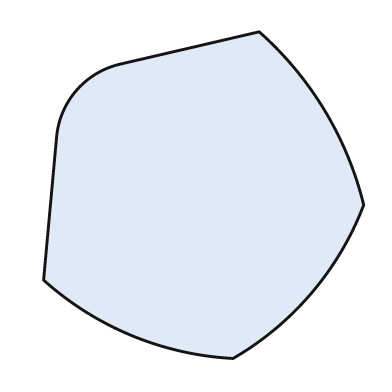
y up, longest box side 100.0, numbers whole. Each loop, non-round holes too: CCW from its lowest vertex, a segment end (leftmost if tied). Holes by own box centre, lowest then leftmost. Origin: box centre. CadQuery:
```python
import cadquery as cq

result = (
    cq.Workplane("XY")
    .moveTo(9.0, -50.0)
    .threePointArc((33.0, -30.0), (49.0, -3.0))
    .threePointArc((37.0, 26.0), (17.0, 50.0))
    .lineTo(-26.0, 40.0)
    .threePointArc((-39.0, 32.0), (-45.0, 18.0))
    .lineTo(-49.0, -26.0)
    .threePointArc((-22.0, -43.0), (9.0, -50.0))
    .close()
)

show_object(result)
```